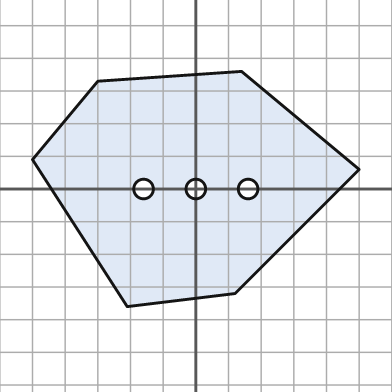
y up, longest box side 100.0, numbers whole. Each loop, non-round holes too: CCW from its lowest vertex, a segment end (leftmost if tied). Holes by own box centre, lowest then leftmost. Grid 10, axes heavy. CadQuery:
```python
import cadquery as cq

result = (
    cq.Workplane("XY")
    .moveTo(-21.0, -36.0)
    .lineTo(12.0, -32.0)
    .lineTo(50.0, 6.0)
    .lineTo(14.0, 36.0)
    .lineTo(-30.0, 33.0)
    .lineTo(-50.0, 9.0)
    .close()
    .moveTo(-16.0, 0.0)
    .circle(3.0)
    .moveTo(0.0, 0.0)
    .circle(3.0)
    .moveTo(16.0, 0.0)
    .circle(3.0)
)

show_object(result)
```